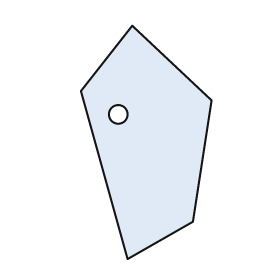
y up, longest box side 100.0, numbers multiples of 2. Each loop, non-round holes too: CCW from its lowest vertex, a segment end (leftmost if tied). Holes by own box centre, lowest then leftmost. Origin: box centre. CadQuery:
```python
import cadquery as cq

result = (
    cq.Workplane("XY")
    .moveTo(-8.0, -50.0)
    .lineTo(20.0, -34.0)
    .lineTo(28.0, 18.0)
    .lineTo(-6.0, 50.0)
    .lineTo(-28.0, 22.0)
    .close()
    .moveTo(-12.0, 12.0)
    .circle(4.0)
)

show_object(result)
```